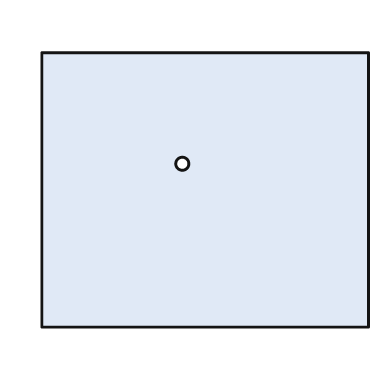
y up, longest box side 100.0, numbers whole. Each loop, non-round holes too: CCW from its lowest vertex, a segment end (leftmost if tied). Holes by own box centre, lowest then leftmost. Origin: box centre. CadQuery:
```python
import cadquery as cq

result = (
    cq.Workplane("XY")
    .moveTo(-50.0, -42.0)
    .lineTo(50.0, -42.0)
    .lineTo(50.0, 42.0)
    .lineTo(-50.0, 42.0)
    .close()
    .moveTo(-7.0, 8.0)
    .circle(2.0)
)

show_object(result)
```